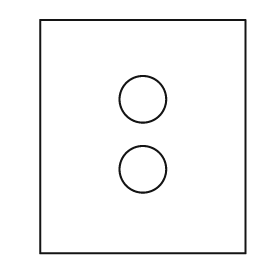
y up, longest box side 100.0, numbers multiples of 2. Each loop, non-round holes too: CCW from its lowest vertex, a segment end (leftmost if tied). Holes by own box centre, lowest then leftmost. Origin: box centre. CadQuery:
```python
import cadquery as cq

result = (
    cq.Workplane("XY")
    .moveTo(-44.0, -50.0)
    .lineTo(44.0, -50.0)
    .lineTo(44.0, 50.0)
    .lineTo(-44.0, 50.0)
    .close()
    .moveTo(0.0, -14.0)
    .circle(10.0)
    .moveTo(0.0, 16.0)
    .circle(10.0)
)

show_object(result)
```